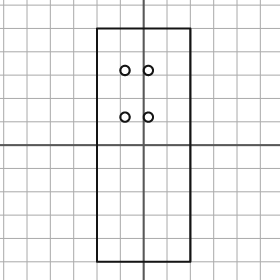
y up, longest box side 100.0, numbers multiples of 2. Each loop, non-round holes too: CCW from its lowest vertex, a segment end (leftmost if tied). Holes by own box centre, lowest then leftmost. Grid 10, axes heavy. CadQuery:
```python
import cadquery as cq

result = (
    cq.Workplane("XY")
    .moveTo(-20.0, -50.0)
    .lineTo(20.0, -50.0)
    .lineTo(20.0, 50.0)
    .lineTo(-20.0, 50.0)
    .close()
    .moveTo(-8.0, 12.0)
    .circle(2.0)
    .moveTo(2.0, 12.0)
    .circle(2.0)
    .moveTo(-8.0, 32.0)
    .circle(2.0)
    .moveTo(2.0, 32.0)
    .circle(2.0)
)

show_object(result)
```